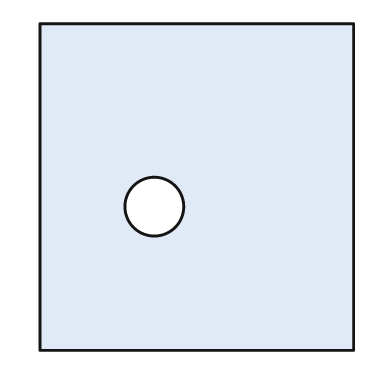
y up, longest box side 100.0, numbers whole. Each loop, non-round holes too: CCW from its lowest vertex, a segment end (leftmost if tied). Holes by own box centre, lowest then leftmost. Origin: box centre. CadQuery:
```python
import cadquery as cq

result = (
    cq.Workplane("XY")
    .moveTo(-48.0, -50.0)
    .lineTo(48.0, -50.0)
    .lineTo(48.0, 50.0)
    .lineTo(-48.0, 50.0)
    .close()
    .moveTo(-13.0, -6.0)
    .circle(9.0)
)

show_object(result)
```